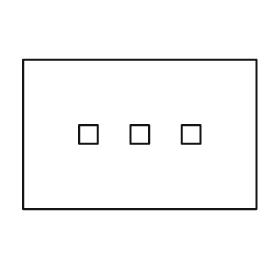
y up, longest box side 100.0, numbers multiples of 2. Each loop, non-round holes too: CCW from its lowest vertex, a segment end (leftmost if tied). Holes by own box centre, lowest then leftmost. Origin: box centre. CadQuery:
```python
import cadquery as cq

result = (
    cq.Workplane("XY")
    .moveTo(-50.0, -32.0)
    .lineTo(50.0, -32.0)
    .lineTo(50.0, 32.0)
    .lineTo(-50.0, 32.0)
    .close()
    .moveTo(-26.0, -4.0)
    .lineTo(-18.0, -4.0)
    .lineTo(-18.0, 4.0)
    .lineTo(-26.0, 4.0)
    .close()
    .moveTo(-4.0, -4.0)
    .lineTo(4.0, -4.0)
    .lineTo(4.0, 4.0)
    .lineTo(-4.0, 4.0)
    .close()
    .moveTo(18.0, -4.0)
    .lineTo(26.0, -4.0)
    .lineTo(26.0, 4.0)
    .lineTo(18.0, 4.0)
    .close()
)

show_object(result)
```